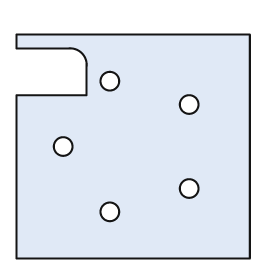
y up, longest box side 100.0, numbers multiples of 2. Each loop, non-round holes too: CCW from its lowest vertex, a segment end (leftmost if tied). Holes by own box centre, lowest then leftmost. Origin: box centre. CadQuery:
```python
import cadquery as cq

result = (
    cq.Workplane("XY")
    .moveTo(-50.0, -48.0)
    .lineTo(50.0, -48.0)
    .lineTo(50.0, 48.0)
    .lineTo(-50.0, 48.0)
    .lineTo(-50.0, 42.0)
    .lineTo(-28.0, 42.0)
    .threePointArc((-22.0, 40.0), (-20.0, 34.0))
    .lineTo(-20.0, 22.0)
    .lineTo(-50.0, 22.0)
    .close()
    .moveTo(-10.0, -28.0)
    .circle(4.0)
    .moveTo(24.0, -18.0)
    .circle(4.0)
    .moveTo(-30.0, 0.0)
    .circle(4.0)
    .moveTo(24.0, 18.0)
    .circle(4.0)
    .moveTo(-10.0, 28.0)
    .circle(4.0)
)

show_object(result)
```